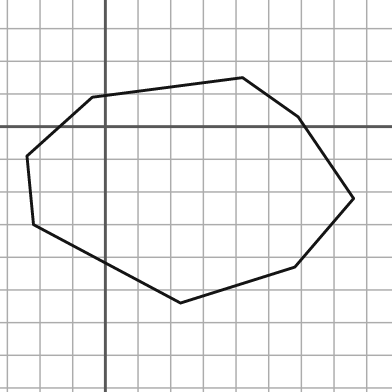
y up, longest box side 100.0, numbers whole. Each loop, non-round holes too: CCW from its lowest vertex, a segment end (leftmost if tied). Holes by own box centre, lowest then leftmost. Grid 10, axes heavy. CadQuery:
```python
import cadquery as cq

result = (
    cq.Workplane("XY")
    .moveTo(23.0, -54.0)
    .lineTo(58.0, -43.0)
    .lineTo(76.0, -22.0)
    .lineTo(59.0, 3.0)
    .lineTo(42.0, 15.0)
    .lineTo(-4.0, 9.0)
    .lineTo(-24.0, -9.0)
    .lineTo(-22.0, -30.0)
    .close()
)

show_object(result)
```